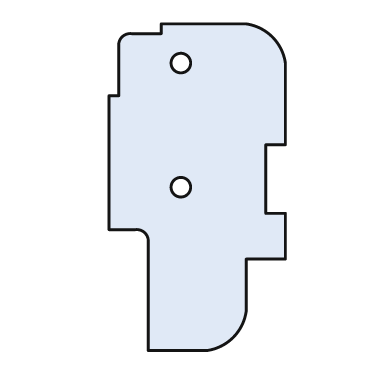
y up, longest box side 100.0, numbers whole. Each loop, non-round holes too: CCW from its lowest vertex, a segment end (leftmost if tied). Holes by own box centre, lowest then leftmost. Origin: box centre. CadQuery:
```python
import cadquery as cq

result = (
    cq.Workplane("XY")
    .moveTo(-15.0, -50.0)
    .lineTo(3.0, -50.0)
    .threePointArc((11.0, -46.0), (15.0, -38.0))
    .lineTo(15.0, -22.0)
    .lineTo(27.0, -22.0)
    .lineTo(27.0, -8.0)
    .lineTo(21.0, -8.0)
    .lineTo(21.0, 13.0)
    .lineTo(27.0, 13.0)
    .lineTo(27.0, 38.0)
    .threePointArc((23.0, 46.0), (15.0, 50.0))
    .lineTo(-11.0, 50.0)
    .lineTo(-11.0, 47.0)
    .lineTo(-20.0, 47.0)
    .threePointArc((-23.0, 46.0), (-24.0, 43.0))
    .lineTo(-24.0, 28.0)
    .lineTo(-27.0, 28.0)
    .lineTo(-27.0, -13.0)
    .lineTo(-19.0, -13.0)
    .threePointArc((-16.0, -14.0), (-15.0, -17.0))
    .close()
    .moveTo(-5.0, 0.0)
    .circle(3.0)
    .moveTo(-5.0, 38.0)
    .circle(3.0)
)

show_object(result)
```